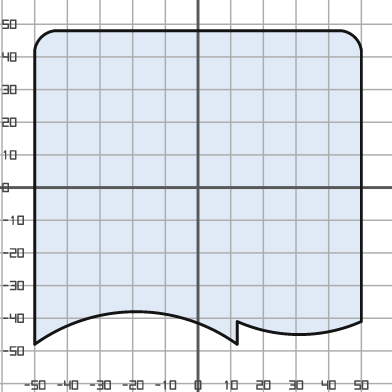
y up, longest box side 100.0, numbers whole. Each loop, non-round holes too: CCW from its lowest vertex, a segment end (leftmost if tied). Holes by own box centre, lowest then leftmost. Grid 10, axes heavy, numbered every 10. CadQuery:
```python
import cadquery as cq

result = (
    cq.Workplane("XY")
    .moveTo(-50.0, -48.0)
    .threePointArc((-19.0, -38.0), (12.0, -48.0))
    .lineTo(12.0, -41.0)
    .threePointArc((31.0, -45.0), (50.0, -41.0))
    .lineTo(50.0, 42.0)
    .threePointArc((48.0, 46.0), (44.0, 48.0))
    .lineTo(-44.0, 48.0)
    .threePointArc((-48.0, 46.0), (-50.0, 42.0))
    .close()
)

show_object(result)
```